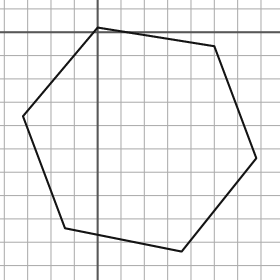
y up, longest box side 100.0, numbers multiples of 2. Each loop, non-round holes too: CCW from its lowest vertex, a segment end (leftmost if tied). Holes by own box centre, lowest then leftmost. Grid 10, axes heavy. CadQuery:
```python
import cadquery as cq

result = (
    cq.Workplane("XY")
    .moveTo(36.0, -94.0)
    .lineTo(68.0, -54.0)
    .lineTo(50.0, -6.0)
    .lineTo(0.0, 2.0)
    .lineTo(-32.0, -36.0)
    .lineTo(-14.0, -84.0)
    .close()
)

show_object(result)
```